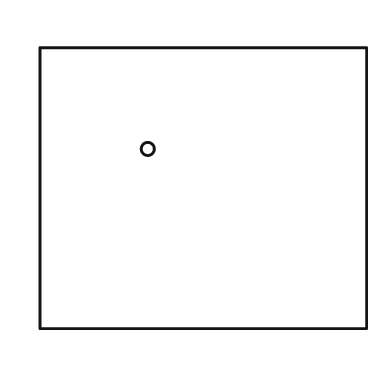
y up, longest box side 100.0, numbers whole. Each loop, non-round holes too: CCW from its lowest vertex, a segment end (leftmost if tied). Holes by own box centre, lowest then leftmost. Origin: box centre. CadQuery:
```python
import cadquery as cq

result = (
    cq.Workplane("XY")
    .moveTo(-50.0, -43.0)
    .lineTo(50.0, -43.0)
    .lineTo(50.0, 43.0)
    .lineTo(-50.0, 43.0)
    .close()
    .moveTo(-17.0, 12.0)
    .circle(2.0)
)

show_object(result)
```